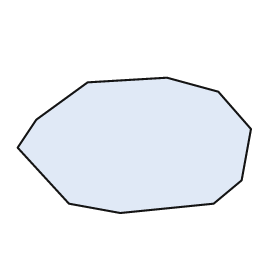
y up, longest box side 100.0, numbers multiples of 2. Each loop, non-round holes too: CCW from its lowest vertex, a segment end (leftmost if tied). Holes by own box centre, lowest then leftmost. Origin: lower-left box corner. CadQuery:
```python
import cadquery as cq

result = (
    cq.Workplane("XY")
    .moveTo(44.0, 0.0)
    .lineTo(84.0, 4.0)
    .lineTo(96.0, 14.0)
    .lineTo(100.0, 36.0)
    .lineTo(86.0, 52.0)
    .lineTo(64.0, 58.0)
    .lineTo(30.0, 56.0)
    .lineTo(8.0, 40.0)
    .lineTo(0.0, 28.0)
    .lineTo(22.0, 4.0)
    .close()
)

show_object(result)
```